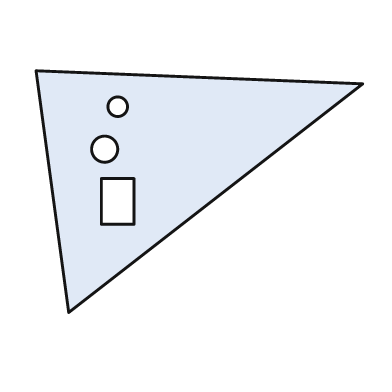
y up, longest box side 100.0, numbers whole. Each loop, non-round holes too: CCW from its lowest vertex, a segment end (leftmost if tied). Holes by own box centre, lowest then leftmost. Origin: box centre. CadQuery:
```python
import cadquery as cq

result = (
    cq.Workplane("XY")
    .moveTo(-40.0, -37.0)
    .lineTo(50.0, 33.0)
    .lineTo(-50.0, 37.0)
    .close()
    .moveTo(-30.0, -10.0)
    .lineTo(-20.0, -10.0)
    .lineTo(-20.0, 4.0)
    .lineTo(-30.0, 4.0)
    .close()
    .moveTo(-29.0, 13.0)
    .circle(4.0)
    .moveTo(-25.0, 26.0)
    .circle(3.0)
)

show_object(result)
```